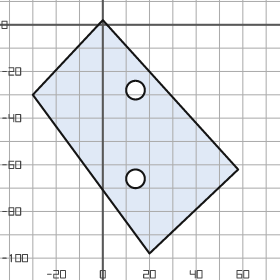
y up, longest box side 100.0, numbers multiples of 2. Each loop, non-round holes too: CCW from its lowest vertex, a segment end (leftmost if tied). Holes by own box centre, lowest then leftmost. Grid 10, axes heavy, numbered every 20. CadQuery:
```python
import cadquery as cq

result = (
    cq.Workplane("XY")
    .moveTo(20.0, -98.0)
    .lineTo(58.0, -62.0)
    .lineTo(0.0, 2.0)
    .lineTo(-30.0, -30.0)
    .close()
    .moveTo(14.0, -66.0)
    .circle(4.0)
    .moveTo(14.0, -28.0)
    .circle(4.0)
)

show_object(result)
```